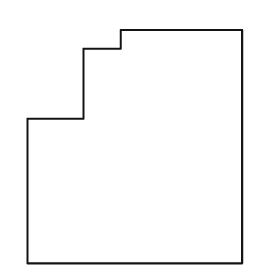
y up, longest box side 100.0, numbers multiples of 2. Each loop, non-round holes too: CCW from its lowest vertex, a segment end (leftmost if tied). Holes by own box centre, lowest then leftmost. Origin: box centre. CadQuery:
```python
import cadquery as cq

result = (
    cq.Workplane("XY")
    .moveTo(-46.0, -50.0)
    .lineTo(46.0, -50.0)
    .lineTo(46.0, 50.0)
    .lineTo(-6.0, 50.0)
    .lineTo(-6.0, 42.0)
    .lineTo(-22.0, 42.0)
    .lineTo(-22.0, 12.0)
    .lineTo(-46.0, 12.0)
    .close()
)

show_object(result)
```